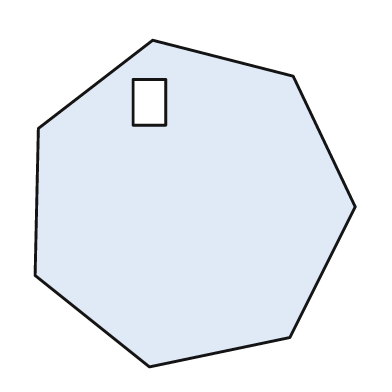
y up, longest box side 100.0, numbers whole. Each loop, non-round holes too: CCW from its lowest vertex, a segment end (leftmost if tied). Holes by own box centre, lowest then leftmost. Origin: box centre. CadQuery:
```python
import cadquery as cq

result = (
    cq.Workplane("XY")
    .moveTo(-14.0, -50.0)
    .lineTo(29.0, -41.0)
    .lineTo(49.0, -1.0)
    .lineTo(30.0, 39.0)
    .lineTo(-13.0, 50.0)
    .lineTo(-48.0, 23.0)
    .lineTo(-49.0, -22.0)
    .close()
    .moveTo(-19.0, 24.0)
    .lineTo(-9.0, 24.0)
    .lineTo(-9.0, 38.0)
    .lineTo(-19.0, 38.0)
    .close()
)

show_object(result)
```